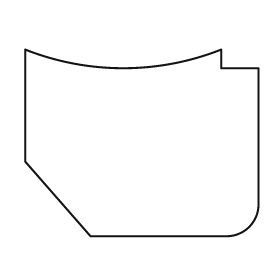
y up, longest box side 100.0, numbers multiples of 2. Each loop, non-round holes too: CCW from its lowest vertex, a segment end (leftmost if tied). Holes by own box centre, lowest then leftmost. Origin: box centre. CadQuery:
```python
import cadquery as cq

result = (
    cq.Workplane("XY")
    .moveTo(-22.0, -40.0)
    .lineTo(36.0, -40.0)
    .threePointArc((46.0, -36.0), (50.0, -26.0))
    .lineTo(50.0, 32.0)
    .lineTo(34.0, 32.0)
    .lineTo(34.0, 40.0)
    .threePointArc((-8.0, 32.0), (-50.0, 40.0))
    .lineTo(-50.0, -8.0)
    .close()
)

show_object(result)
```